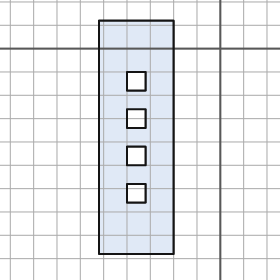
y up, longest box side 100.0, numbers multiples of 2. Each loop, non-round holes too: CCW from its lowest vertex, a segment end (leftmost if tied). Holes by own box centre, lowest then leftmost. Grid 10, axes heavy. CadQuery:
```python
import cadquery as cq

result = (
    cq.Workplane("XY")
    .moveTo(-52.0, -88.0)
    .lineTo(-20.0, -88.0)
    .lineTo(-20.0, 12.0)
    .lineTo(-52.0, 12.0)
    .close()
    .moveTo(-40.0, -66.0)
    .lineTo(-32.0, -66.0)
    .lineTo(-32.0, -58.0)
    .lineTo(-40.0, -58.0)
    .close()
    .moveTo(-40.0, -50.0)
    .lineTo(-32.0, -50.0)
    .lineTo(-32.0, -42.0)
    .lineTo(-40.0, -42.0)
    .close()
    .moveTo(-40.0, -34.0)
    .lineTo(-32.0, -34.0)
    .lineTo(-32.0, -26.0)
    .lineTo(-40.0, -26.0)
    .close()
    .moveTo(-40.0, -18.0)
    .lineTo(-32.0, -18.0)
    .lineTo(-32.0, -10.0)
    .lineTo(-40.0, -10.0)
    .close()
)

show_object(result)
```